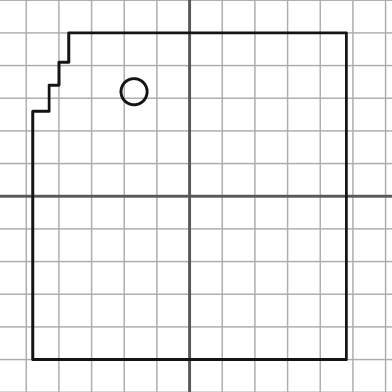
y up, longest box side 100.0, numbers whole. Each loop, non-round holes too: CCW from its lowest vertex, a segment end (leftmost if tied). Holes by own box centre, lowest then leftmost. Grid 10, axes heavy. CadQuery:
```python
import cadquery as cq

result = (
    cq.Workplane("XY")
    .moveTo(-48.0, -50.0)
    .lineTo(48.0, -50.0)
    .lineTo(48.0, 50.0)
    .lineTo(-37.0, 50.0)
    .lineTo(-37.0, 41.0)
    .lineTo(-40.0, 41.0)
    .lineTo(-40.0, 34.0)
    .lineTo(-43.0, 34.0)
    .lineTo(-43.0, 26.0)
    .lineTo(-48.0, 26.0)
    .close()
    .moveTo(-17.0, 32.0)
    .circle(4.0)
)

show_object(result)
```